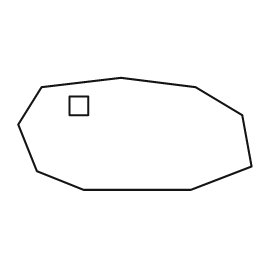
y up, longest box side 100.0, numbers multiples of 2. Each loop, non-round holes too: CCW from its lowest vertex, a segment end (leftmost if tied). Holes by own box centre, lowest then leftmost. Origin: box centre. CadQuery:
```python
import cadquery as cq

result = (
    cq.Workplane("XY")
    .moveTo(-22.0, -24.0)
    .lineTo(24.0, -24.0)
    .lineTo(50.0, -14.0)
    .lineTo(46.0, 8.0)
    .lineTo(26.0, 20.0)
    .lineTo(-6.0, 24.0)
    .lineTo(-40.0, 20.0)
    .lineTo(-50.0, 4.0)
    .lineTo(-42.0, -16.0)
    .close()
    .moveTo(-28.0, 8.0)
    .lineTo(-20.0, 8.0)
    .lineTo(-20.0, 16.0)
    .lineTo(-28.0, 16.0)
    .close()
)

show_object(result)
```